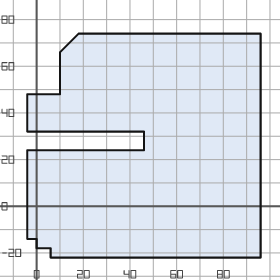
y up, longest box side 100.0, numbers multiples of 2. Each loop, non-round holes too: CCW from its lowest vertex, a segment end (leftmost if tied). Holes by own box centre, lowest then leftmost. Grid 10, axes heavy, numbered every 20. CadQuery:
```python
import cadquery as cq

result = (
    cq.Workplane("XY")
    .moveTo(6.0, -22.0)
    .lineTo(96.0, -22.0)
    .lineTo(96.0, 74.0)
    .lineTo(18.0, 74.0)
    .lineTo(10.0, 66.0)
    .lineTo(10.0, 48.0)
    .lineTo(-4.0, 48.0)
    .lineTo(-4.0, 32.0)
    .lineTo(46.0, 32.0)
    .lineTo(46.0, 24.0)
    .lineTo(-4.0, 24.0)
    .lineTo(-4.0, -14.0)
    .lineTo(0.0, -14.0)
    .lineTo(0.0, -18.0)
    .lineTo(6.0, -18.0)
    .close()
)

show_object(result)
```